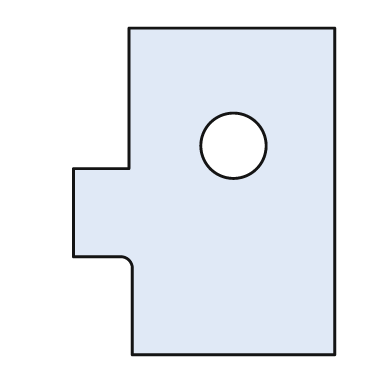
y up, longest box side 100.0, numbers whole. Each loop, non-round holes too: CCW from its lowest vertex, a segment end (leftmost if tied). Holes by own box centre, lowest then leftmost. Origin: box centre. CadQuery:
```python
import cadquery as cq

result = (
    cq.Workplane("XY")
    .moveTo(-22.0, -50.0)
    .lineTo(40.0, -50.0)
    .lineTo(40.0, 50.0)
    .lineTo(-23.0, 50.0)
    .lineTo(-23.0, 7.0)
    .lineTo(-40.0, 7.0)
    .lineTo(-40.0, -20.0)
    .lineTo(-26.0, -20.0)
    .threePointArc((-23.0, -21.0), (-22.0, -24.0))
    .close()
    .moveTo(9.0, 14.0)
    .circle(10.0)
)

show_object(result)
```